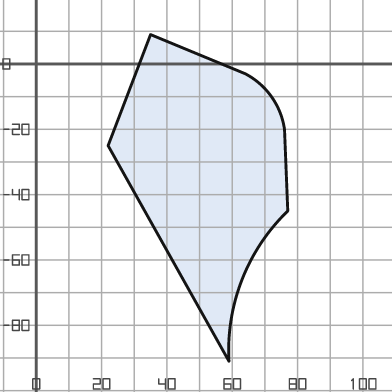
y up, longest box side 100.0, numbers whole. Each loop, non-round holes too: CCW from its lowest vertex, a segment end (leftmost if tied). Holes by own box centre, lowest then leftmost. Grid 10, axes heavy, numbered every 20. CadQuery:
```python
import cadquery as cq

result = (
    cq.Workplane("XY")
    .moveTo(59.0, -91.0)
    .threePointArc((63.0, -66.0), (77.0, -45.0))
    .lineTo(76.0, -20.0)
    .threePointArc((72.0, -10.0), (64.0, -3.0))
    .lineTo(35.0, 9.0)
    .lineTo(22.0, -25.0)
    .close()
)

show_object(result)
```